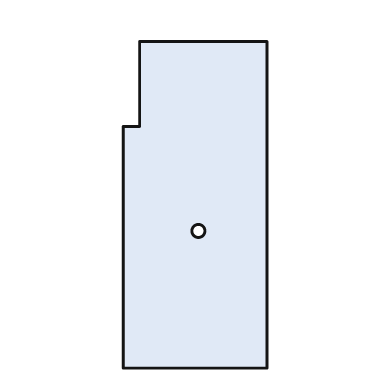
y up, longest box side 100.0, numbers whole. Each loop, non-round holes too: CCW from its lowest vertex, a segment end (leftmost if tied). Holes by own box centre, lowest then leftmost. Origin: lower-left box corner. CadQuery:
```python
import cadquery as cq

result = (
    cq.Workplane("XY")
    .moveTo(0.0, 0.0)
    .lineTo(44.0, 0.0)
    .lineTo(44.0, 100.0)
    .lineTo(5.0, 100.0)
    .lineTo(5.0, 74.0)
    .lineTo(0.0, 74.0)
    .close()
    .moveTo(23.0, 42.0)
    .circle(2.0)
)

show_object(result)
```